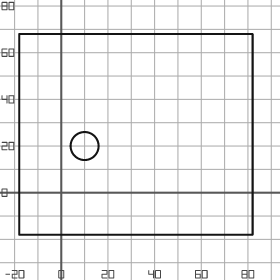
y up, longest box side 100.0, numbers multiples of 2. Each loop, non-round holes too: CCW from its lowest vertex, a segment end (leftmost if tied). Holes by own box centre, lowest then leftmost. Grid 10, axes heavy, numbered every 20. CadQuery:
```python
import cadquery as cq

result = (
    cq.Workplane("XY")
    .moveTo(-18.0, -18.0)
    .lineTo(82.0, -18.0)
    .lineTo(82.0, 68.0)
    .lineTo(-18.0, 68.0)
    .close()
    .moveTo(10.0, 20.0)
    .circle(6.0)
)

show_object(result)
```